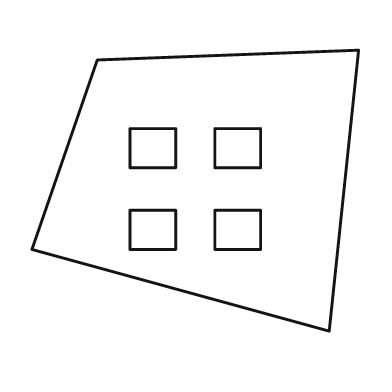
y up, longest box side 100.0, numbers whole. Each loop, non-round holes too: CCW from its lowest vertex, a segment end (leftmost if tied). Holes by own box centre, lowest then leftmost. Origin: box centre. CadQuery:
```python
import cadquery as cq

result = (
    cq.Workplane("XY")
    .moveTo(41.0, -43.0)
    .lineTo(50.0, 43.0)
    .lineTo(-30.0, 40.0)
    .lineTo(-50.0, -18.0)
    .close()
    .moveTo(-20.0, -18.0)
    .lineTo(-6.0, -18.0)
    .lineTo(-6.0, -6.0)
    .lineTo(-20.0, -6.0)
    .close()
    .moveTo(6.0, -18.0)
    .lineTo(20.0, -18.0)
    .lineTo(20.0, -6.0)
    .lineTo(6.0, -6.0)
    .close()
    .moveTo(-20.0, 7.0)
    .lineTo(-6.0, 7.0)
    .lineTo(-6.0, 19.0)
    .lineTo(-20.0, 19.0)
    .close()
    .moveTo(6.0, 7.0)
    .lineTo(20.0, 7.0)
    .lineTo(20.0, 19.0)
    .lineTo(6.0, 19.0)
    .close()
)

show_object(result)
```